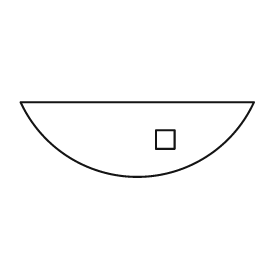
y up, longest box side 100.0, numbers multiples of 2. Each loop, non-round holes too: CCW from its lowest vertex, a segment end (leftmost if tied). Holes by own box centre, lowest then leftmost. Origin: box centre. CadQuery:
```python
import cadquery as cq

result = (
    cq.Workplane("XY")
    .moveTo(-50.0, 16.0)
    .threePointArc((0.0, -16.0), (50.0, 16.0))
    .close()
    .moveTo(8.0, -4.0)
    .lineTo(16.0, -4.0)
    .lineTo(16.0, 4.0)
    .lineTo(8.0, 4.0)
    .close()
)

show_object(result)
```